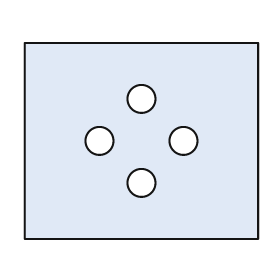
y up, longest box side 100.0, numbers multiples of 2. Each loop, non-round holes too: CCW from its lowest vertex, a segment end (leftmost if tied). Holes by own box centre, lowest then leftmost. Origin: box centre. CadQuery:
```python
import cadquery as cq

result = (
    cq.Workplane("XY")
    .moveTo(-50.0, -42.0)
    .lineTo(50.0, -42.0)
    .lineTo(50.0, 42.0)
    .lineTo(-50.0, 42.0)
    .close()
    .moveTo(0.0, -18.0)
    .circle(6.0)
    .moveTo(-18.0, 0.0)
    .circle(6.0)
    .moveTo(18.0, 0.0)
    .circle(6.0)
    .moveTo(0.0, 18.0)
    .circle(6.0)
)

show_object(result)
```